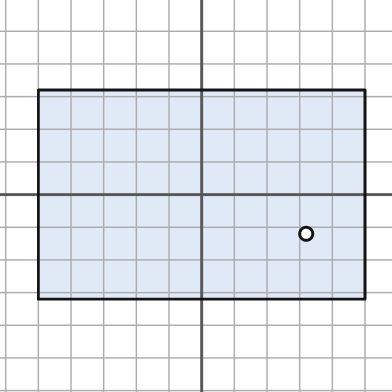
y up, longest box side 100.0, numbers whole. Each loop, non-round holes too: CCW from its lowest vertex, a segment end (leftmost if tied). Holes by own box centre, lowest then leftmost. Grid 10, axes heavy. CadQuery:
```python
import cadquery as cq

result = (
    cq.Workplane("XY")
    .moveTo(-50.0, -32.0)
    .lineTo(50.0, -32.0)
    .lineTo(50.0, 32.0)
    .lineTo(-50.0, 32.0)
    .close()
    .moveTo(32.0, -12.0)
    .circle(2.0)
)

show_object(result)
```